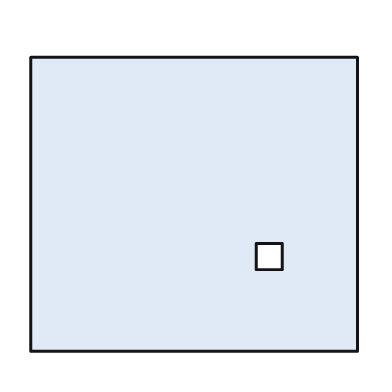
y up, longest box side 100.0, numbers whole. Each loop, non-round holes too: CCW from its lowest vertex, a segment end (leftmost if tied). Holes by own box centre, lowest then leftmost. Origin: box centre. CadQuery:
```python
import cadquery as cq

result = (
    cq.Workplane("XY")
    .moveTo(-50.0, -45.0)
    .lineTo(50.0, -45.0)
    .lineTo(50.0, 45.0)
    .lineTo(-50.0, 45.0)
    .close()
    .moveTo(19.0, -20.0)
    .lineTo(27.0, -20.0)
    .lineTo(27.0, -12.0)
    .lineTo(19.0, -12.0)
    .close()
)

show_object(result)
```